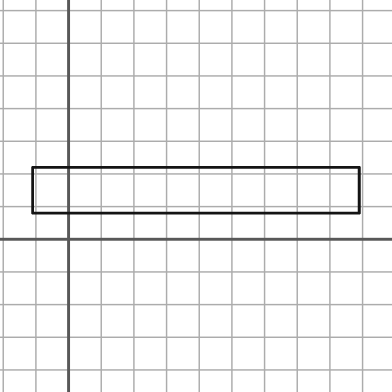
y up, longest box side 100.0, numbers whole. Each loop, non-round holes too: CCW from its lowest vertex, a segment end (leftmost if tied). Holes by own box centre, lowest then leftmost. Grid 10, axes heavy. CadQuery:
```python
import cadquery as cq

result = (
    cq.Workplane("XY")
    .moveTo(-11.0, 8.0)
    .lineTo(89.0, 8.0)
    .lineTo(89.0, 22.0)
    .lineTo(-11.0, 22.0)
    .close()
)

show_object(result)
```